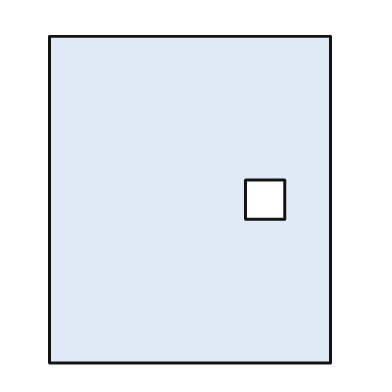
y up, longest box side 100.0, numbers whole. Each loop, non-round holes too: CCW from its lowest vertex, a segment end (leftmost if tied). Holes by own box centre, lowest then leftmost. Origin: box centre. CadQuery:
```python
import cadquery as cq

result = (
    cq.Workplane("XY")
    .moveTo(-43.0, -50.0)
    .lineTo(43.0, -50.0)
    .lineTo(43.0, 50.0)
    .lineTo(-43.0, 50.0)
    .close()
    .moveTo(17.0, -6.0)
    .lineTo(29.0, -6.0)
    .lineTo(29.0, 6.0)
    .lineTo(17.0, 6.0)
    .close()
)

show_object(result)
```